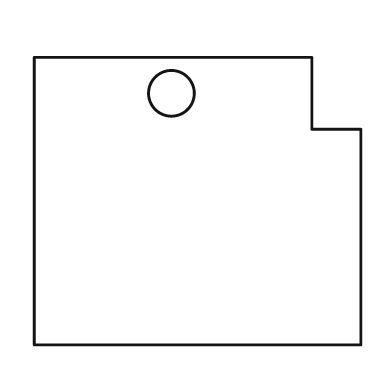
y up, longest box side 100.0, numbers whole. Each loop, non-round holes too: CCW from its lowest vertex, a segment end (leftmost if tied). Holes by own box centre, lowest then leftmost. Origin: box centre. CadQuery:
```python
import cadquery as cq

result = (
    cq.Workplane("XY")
    .moveTo(-50.0, -44.0)
    .lineTo(50.0, -44.0)
    .lineTo(50.0, 22.0)
    .lineTo(35.0, 22.0)
    .lineTo(35.0, 44.0)
    .lineTo(-50.0, 44.0)
    .close()
    .moveTo(-8.0, 33.0)
    .circle(7.0)
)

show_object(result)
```